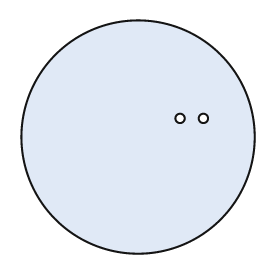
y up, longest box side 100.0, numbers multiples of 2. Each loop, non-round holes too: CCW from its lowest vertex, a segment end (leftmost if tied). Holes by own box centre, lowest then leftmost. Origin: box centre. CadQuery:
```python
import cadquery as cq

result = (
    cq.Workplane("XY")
    .moveTo(0.0, 0.0)
    .circle(50.0)
    .moveTo(18.0, 8.0)
    .circle(2.0)
    .moveTo(28.0, 8.0)
    .circle(2.0)
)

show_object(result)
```